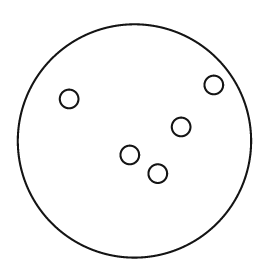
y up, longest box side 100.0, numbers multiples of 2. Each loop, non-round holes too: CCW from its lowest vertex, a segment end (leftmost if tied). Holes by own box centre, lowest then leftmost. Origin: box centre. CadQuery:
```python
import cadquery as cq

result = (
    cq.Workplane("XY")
    .moveTo(0.0, 0.0)
    .circle(50.0)
    .moveTo(10.0, -14.0)
    .circle(4.0)
    .moveTo(-2.0, -6.0)
    .circle(4.0)
    .moveTo(20.0, 6.0)
    .circle(4.0)
    .moveTo(-28.0, 18.0)
    .circle(4.0)
    .moveTo(34.0, 24.0)
    .circle(4.0)
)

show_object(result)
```